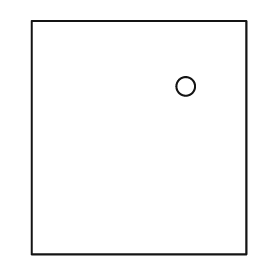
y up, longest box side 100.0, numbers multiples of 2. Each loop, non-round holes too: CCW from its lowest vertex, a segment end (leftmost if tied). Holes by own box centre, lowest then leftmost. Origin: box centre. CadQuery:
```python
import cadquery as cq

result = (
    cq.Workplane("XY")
    .moveTo(-46.0, -50.0)
    .lineTo(46.0, -50.0)
    .lineTo(46.0, 50.0)
    .lineTo(-46.0, 50.0)
    .close()
    .moveTo(20.0, 22.0)
    .circle(4.0)
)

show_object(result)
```